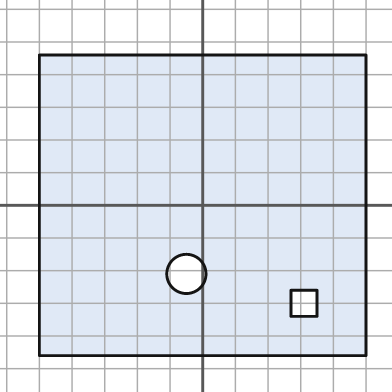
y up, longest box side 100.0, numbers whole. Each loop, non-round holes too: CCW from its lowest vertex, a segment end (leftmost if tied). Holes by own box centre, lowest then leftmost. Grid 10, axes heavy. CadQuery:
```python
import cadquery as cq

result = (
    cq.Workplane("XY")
    .moveTo(-50.0, -46.0)
    .lineTo(50.0, -46.0)
    .lineTo(50.0, 46.0)
    .lineTo(-50.0, 46.0)
    .close()
    .moveTo(27.0, -34.0)
    .lineTo(35.0, -34.0)
    .lineTo(35.0, -26.0)
    .lineTo(27.0, -26.0)
    .close()
    .moveTo(-5.0, -21.0)
    .circle(6.0)
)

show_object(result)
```